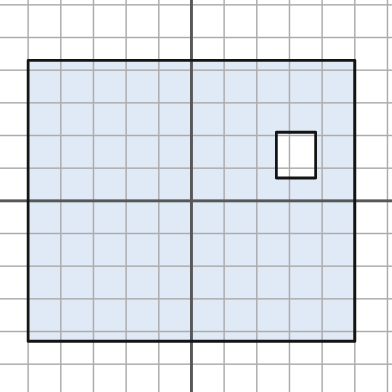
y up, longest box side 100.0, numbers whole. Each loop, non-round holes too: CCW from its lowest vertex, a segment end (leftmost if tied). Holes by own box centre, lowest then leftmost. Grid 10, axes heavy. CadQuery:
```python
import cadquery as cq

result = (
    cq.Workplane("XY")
    .moveTo(-50.0, -43.0)
    .lineTo(50.0, -43.0)
    .lineTo(50.0, 43.0)
    .lineTo(-50.0, 43.0)
    .close()
    .moveTo(26.0, 7.0)
    .lineTo(38.0, 7.0)
    .lineTo(38.0, 21.0)
    .lineTo(26.0, 21.0)
    .close()
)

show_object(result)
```